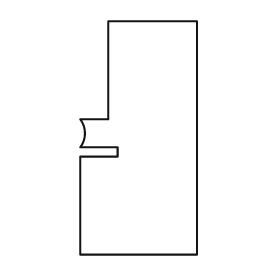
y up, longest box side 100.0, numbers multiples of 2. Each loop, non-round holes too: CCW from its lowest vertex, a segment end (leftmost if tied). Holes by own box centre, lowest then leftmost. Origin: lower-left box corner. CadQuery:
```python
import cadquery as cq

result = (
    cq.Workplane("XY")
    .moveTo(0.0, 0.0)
    .lineTo(50.0, 0.0)
    .lineTo(50.0, 100.0)
    .lineTo(12.0, 100.0)
    .lineTo(12.0, 58.0)
    .lineTo(0.0, 58.0)
    .threePointArc((2.0, 52.0), (0.0, 46.0))
    .lineTo(16.0, 46.0)
    .lineTo(16.0, 42.0)
    .lineTo(0.0, 42.0)
    .close()
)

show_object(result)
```